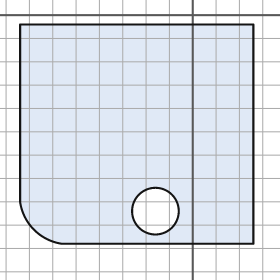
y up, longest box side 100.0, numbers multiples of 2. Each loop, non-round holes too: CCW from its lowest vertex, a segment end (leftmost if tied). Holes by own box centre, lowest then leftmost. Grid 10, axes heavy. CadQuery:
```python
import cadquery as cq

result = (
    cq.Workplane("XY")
    .moveTo(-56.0, -98.0)
    .lineTo(26.0, -98.0)
    .lineTo(26.0, -4.0)
    .lineTo(-74.0, -4.0)
    .lineTo(-74.0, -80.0)
    .threePointArc((-68.0, -92.0), (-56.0, -98.0))
    .close()
    .moveTo(-16.0, -84.0)
    .circle(10.0)
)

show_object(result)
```